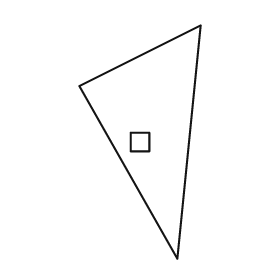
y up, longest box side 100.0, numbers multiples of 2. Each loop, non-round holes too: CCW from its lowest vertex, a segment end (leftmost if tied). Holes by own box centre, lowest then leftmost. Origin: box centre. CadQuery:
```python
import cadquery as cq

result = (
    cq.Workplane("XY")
    .moveTo(16.0, -50.0)
    .lineTo(26.0, 50.0)
    .lineTo(-26.0, 24.0)
    .close()
    .moveTo(-4.0, -4.0)
    .lineTo(4.0, -4.0)
    .lineTo(4.0, 4.0)
    .lineTo(-4.0, 4.0)
    .close()
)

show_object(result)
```